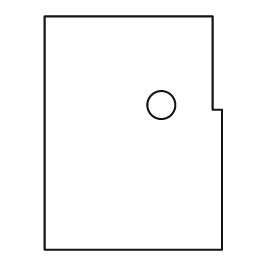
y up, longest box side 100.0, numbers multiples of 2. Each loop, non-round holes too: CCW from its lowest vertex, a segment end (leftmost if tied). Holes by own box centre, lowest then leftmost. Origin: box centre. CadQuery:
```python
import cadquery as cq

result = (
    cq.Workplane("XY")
    .moveTo(-38.0, -50.0)
    .lineTo(38.0, -50.0)
    .lineTo(38.0, 10.0)
    .lineTo(34.0, 10.0)
    .lineTo(34.0, 50.0)
    .lineTo(-38.0, 50.0)
    .close()
    .moveTo(12.0, 12.0)
    .circle(6.0)
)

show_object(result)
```